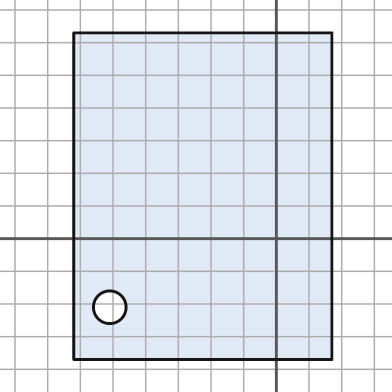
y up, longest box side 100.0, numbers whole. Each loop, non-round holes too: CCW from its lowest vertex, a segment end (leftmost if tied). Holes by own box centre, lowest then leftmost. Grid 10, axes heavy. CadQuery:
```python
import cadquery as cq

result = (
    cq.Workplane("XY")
    .moveTo(-62.0, -37.0)
    .lineTo(17.0, -37.0)
    .lineTo(17.0, 63.0)
    .lineTo(-62.0, 63.0)
    .close()
    .moveTo(-51.0, -21.0)
    .circle(5.0)
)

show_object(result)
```